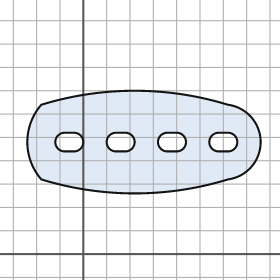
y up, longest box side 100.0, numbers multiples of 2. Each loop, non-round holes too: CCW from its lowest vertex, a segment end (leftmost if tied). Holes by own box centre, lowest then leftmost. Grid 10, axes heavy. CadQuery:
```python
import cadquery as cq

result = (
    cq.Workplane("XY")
    .moveTo(-18.0, 32.0)
    .threePointArc((22.0, 26.0), (62.0, 32.0))
    .threePointArc((76.0, 48.0), (62.0, 64.0))
    .threePointArc((22.0, 70.0), (-18.0, 64.0))
    .threePointArc((-24.0, 48.0), (-18.0, 32.0))
    .close()
    .moveTo(-8.0, 44.0)
    .lineTo(-4.0, 44.0)
    .threePointArc((0.0, 48.0), (-4.0, 52.0))
    .lineTo(-8.0, 52.0)
    .threePointArc((-12.0, 48.0), (-8.0, 44.0))
    .close()
    .moveTo(14.0, 44.0)
    .lineTo(18.0, 44.0)
    .threePointArc((22.0, 48.0), (18.0, 52.0))
    .lineTo(14.0, 52.0)
    .threePointArc((10.0, 48.0), (14.0, 44.0))
    .close()
    .moveTo(36.0, 44.0)
    .lineTo(40.0, 44.0)
    .threePointArc((44.0, 48.0), (40.0, 52.0))
    .lineTo(36.0, 52.0)
    .threePointArc((32.0, 48.0), (36.0, 44.0))
    .close()
    .moveTo(58.0, 44.0)
    .lineTo(62.0, 44.0)
    .threePointArc((66.0, 48.0), (62.0, 52.0))
    .lineTo(58.0, 52.0)
    .threePointArc((54.0, 48.0), (58.0, 44.0))
    .close()
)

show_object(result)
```